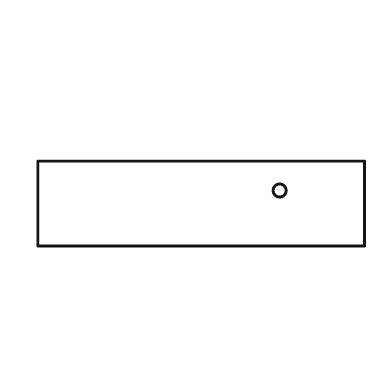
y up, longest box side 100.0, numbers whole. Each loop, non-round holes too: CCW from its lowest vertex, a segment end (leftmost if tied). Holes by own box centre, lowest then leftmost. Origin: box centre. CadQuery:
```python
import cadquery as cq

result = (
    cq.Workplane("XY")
    .moveTo(-50.0, -13.0)
    .lineTo(50.0, -13.0)
    .lineTo(50.0, 13.0)
    .lineTo(-50.0, 13.0)
    .close()
    .moveTo(24.0, 4.0)
    .circle(2.0)
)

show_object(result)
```